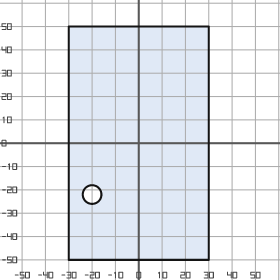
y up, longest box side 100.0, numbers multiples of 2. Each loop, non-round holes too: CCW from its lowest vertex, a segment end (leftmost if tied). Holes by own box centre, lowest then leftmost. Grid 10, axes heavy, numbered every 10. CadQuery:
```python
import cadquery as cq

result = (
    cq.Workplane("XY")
    .moveTo(-30.0, -50.0)
    .lineTo(30.0, -50.0)
    .lineTo(30.0, 50.0)
    .lineTo(-30.0, 50.0)
    .close()
    .moveTo(-20.0, -22.0)
    .circle(4.0)
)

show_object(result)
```